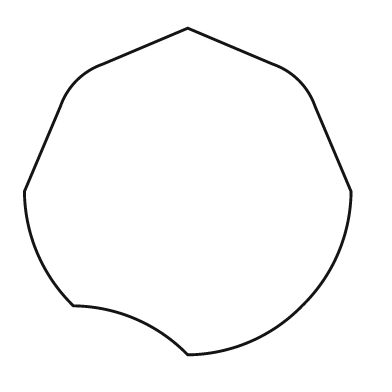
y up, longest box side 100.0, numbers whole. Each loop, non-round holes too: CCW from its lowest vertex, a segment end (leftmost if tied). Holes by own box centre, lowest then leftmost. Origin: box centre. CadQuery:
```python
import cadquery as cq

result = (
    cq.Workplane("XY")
    .moveTo(0.0, -50.0)
    .threePointArc((19.0, -46.0), (35.0, -35.0))
    .threePointArc((46.0, -19.0), (50.0, 0.0))
    .lineTo(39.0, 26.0)
    .threePointArc((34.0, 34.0), (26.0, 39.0))
    .lineTo(0.0, 50.0)
    .lineTo(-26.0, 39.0)
    .threePointArc((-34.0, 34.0), (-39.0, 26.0))
    .lineTo(-50.0, 0.0)
    .threePointArc((-46.0, -19.0), (-35.0, -35.0))
    .threePointArc((-16.0, -39.0), (0.0, -50.0))
    .close()
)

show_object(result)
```